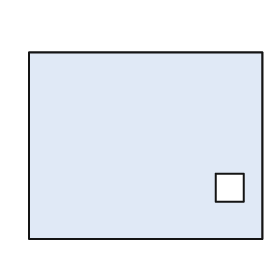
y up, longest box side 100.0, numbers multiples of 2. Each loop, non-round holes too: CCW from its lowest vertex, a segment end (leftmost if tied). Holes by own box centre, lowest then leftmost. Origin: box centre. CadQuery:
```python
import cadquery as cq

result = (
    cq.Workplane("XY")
    .moveTo(-50.0, -40.0)
    .lineTo(50.0, -40.0)
    .lineTo(50.0, 40.0)
    .lineTo(-50.0, 40.0)
    .close()
    .moveTo(30.0, -24.0)
    .lineTo(42.0, -24.0)
    .lineTo(42.0, -12.0)
    .lineTo(30.0, -12.0)
    .close()
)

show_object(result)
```